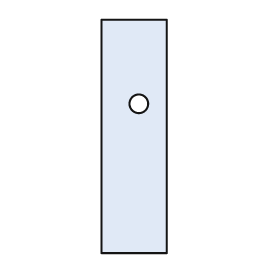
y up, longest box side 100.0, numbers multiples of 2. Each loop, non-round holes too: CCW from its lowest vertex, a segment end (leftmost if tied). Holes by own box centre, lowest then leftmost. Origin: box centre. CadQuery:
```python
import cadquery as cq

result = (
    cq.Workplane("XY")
    .moveTo(-14.0, -50.0)
    .lineTo(14.0, -50.0)
    .lineTo(14.0, 50.0)
    .lineTo(-14.0, 50.0)
    .close()
    .moveTo(2.0, 14.0)
    .circle(4.0)
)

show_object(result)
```